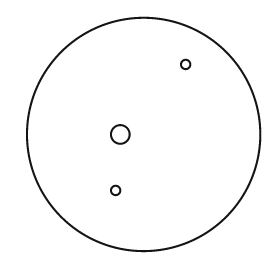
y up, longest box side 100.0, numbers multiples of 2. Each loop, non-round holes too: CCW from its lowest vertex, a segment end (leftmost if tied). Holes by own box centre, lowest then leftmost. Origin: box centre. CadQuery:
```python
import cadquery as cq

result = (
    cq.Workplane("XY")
    .moveTo(0.0, 0.0)
    .circle(50.0)
    .moveTo(-12.0, -24.0)
    .circle(2.0)
    .moveTo(-10.0, 0.0)
    .circle(4.0)
    .moveTo(18.0, 30.0)
    .circle(2.0)
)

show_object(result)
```